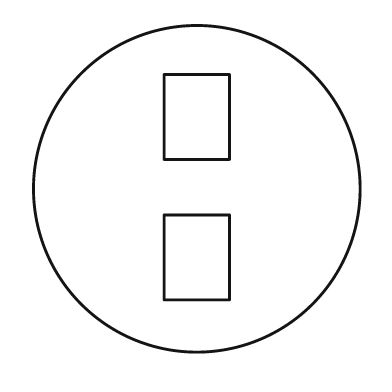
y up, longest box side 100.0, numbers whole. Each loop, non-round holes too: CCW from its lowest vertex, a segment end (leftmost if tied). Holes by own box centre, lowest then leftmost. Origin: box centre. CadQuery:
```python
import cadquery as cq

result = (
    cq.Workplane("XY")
    .moveTo(0.0, 0.0)
    .circle(50.0)
    .moveTo(-10.0, -34.0)
    .lineTo(10.0, -34.0)
    .lineTo(10.0, -8.0)
    .lineTo(-10.0, -8.0)
    .close()
    .moveTo(-10.0, 9.0)
    .lineTo(10.0, 9.0)
    .lineTo(10.0, 35.0)
    .lineTo(-10.0, 35.0)
    .close()
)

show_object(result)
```